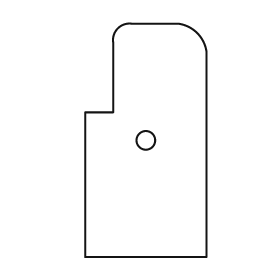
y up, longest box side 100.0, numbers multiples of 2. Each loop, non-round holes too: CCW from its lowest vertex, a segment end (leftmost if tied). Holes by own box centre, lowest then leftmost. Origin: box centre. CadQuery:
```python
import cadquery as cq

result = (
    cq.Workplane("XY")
    .moveTo(-26.0, -50.0)
    .lineTo(26.0, -50.0)
    .lineTo(26.0, 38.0)
    .threePointArc((22.0, 46.0), (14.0, 50.0))
    .lineTo(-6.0, 50.0)
    .threePointArc((-12.0, 48.0), (-14.0, 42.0))
    .lineTo(-14.0, 12.0)
    .lineTo(-26.0, 12.0)
    .close()
    .moveTo(0.0, 0.0)
    .circle(4.0)
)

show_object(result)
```